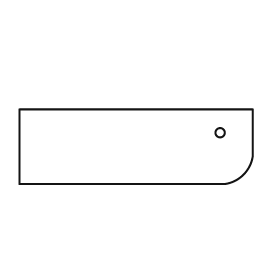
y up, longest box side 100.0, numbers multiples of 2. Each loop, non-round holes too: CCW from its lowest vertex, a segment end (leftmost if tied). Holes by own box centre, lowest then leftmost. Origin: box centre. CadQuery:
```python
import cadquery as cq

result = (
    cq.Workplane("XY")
    .moveTo(-50.0, -16.0)
    .lineTo(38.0, -16.0)
    .threePointArc((46.0, -12.0), (50.0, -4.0))
    .lineTo(50.0, 16.0)
    .lineTo(-50.0, 16.0)
    .close()
    .moveTo(36.0, 6.0)
    .circle(2.0)
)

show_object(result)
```